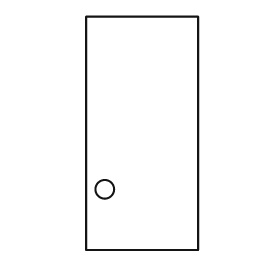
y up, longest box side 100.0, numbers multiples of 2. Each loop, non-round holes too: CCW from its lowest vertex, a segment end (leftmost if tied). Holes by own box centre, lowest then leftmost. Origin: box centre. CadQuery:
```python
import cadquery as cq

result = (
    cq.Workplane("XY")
    .moveTo(-24.0, -50.0)
    .lineTo(24.0, -50.0)
    .lineTo(24.0, 50.0)
    .lineTo(-24.0, 50.0)
    .close()
    .moveTo(-16.0, -24.0)
    .circle(4.0)
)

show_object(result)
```